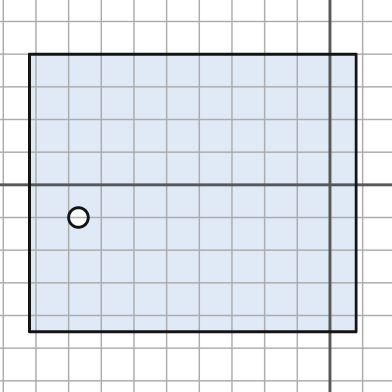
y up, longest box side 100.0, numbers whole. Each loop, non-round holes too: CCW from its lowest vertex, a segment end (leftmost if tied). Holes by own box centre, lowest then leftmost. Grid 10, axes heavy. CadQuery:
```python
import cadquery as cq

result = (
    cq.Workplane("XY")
    .moveTo(-92.0, -45.0)
    .lineTo(8.0, -45.0)
    .lineTo(8.0, 40.0)
    .lineTo(-92.0, 40.0)
    .close()
    .moveTo(-77.0, -10.0)
    .circle(3.0)
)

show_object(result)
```